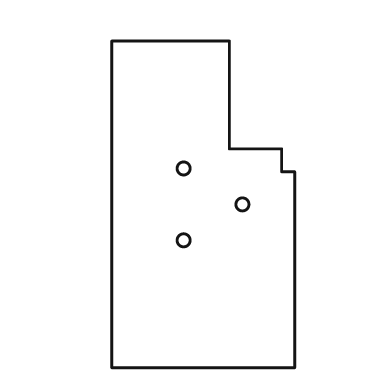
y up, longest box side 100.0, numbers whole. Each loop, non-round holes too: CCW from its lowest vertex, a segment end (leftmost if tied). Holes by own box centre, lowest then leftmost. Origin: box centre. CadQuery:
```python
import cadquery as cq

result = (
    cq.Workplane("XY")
    .moveTo(-28.0, -50.0)
    .lineTo(28.0, -50.0)
    .lineTo(28.0, 10.0)
    .lineTo(24.0, 10.0)
    .lineTo(24.0, 17.0)
    .lineTo(8.0, 17.0)
    .lineTo(8.0, 50.0)
    .lineTo(-28.0, 50.0)
    .close()
    .moveTo(-6.0, -11.0)
    .circle(2.0)
    .moveTo(12.0, 0.0)
    .circle(2.0)
    .moveTo(-6.0, 11.0)
    .circle(2.0)
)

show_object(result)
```